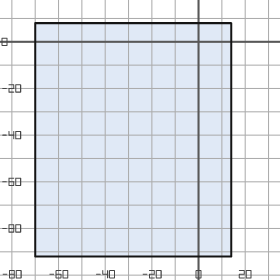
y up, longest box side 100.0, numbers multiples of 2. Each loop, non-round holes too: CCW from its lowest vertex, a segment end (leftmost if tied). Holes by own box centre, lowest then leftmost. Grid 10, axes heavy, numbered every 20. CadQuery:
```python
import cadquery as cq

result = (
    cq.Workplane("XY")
    .moveTo(-70.0, -92.0)
    .lineTo(14.0, -92.0)
    .lineTo(14.0, 8.0)
    .lineTo(-70.0, 8.0)
    .close()
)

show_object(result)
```